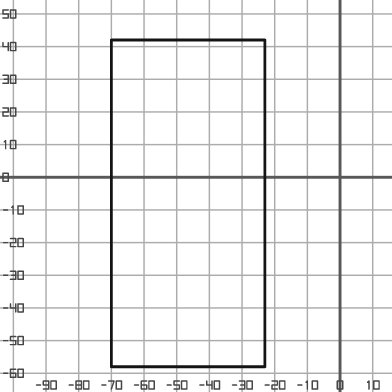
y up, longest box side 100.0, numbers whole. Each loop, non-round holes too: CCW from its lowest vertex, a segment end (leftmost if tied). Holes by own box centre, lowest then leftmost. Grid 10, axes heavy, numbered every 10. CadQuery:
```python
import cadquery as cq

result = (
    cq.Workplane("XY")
    .moveTo(-70.0, -58.0)
    .lineTo(-23.0, -58.0)
    .lineTo(-23.0, 42.0)
    .lineTo(-70.0, 42.0)
    .close()
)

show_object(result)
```